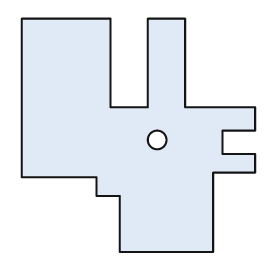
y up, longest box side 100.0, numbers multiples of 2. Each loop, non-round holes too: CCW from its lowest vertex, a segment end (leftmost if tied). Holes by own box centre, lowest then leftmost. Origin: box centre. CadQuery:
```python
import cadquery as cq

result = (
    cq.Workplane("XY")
    .moveTo(-8.0, -50.0)
    .lineTo(32.0, -50.0)
    .lineTo(32.0, -16.0)
    .lineTo(50.0, -16.0)
    .lineTo(50.0, -8.0)
    .lineTo(36.0, -8.0)
    .lineTo(36.0, 2.0)
    .lineTo(50.0, 2.0)
    .lineTo(50.0, 12.0)
    .lineTo(20.0, 12.0)
    .lineTo(20.0, 50.0)
    .lineTo(4.0, 50.0)
    .lineTo(4.0, 12.0)
    .lineTo(-12.0, 12.0)
    .lineTo(-12.0, 50.0)
    .lineTo(-50.0, 50.0)
    .lineTo(-50.0, -18.0)
    .lineTo(-18.0, -18.0)
    .lineTo(-18.0, -26.0)
    .lineTo(-8.0, -26.0)
    .close()
    .moveTo(8.0, -2.0)
    .circle(4.0)
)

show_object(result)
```